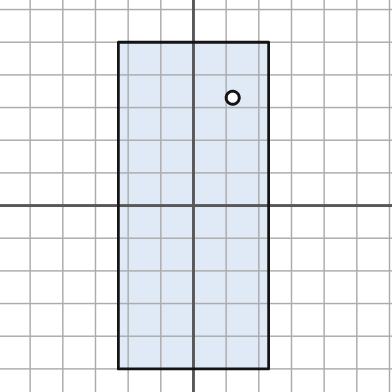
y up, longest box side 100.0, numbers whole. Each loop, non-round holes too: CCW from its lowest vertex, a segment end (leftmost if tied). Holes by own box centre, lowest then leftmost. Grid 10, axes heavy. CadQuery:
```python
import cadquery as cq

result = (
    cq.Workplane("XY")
    .moveTo(-23.0, -50.0)
    .lineTo(23.0, -50.0)
    .lineTo(23.0, 50.0)
    .lineTo(-23.0, 50.0)
    .close()
    .moveTo(12.0, 33.0)
    .circle(2.0)
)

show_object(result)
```